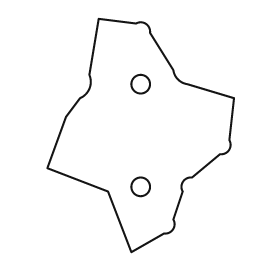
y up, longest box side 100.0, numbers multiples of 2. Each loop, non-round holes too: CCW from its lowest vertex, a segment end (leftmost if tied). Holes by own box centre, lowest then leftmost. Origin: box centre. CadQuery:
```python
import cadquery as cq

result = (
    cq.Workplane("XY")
    .moveTo(-4.0, -50.0)
    .lineTo(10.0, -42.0)
    .threePointArc((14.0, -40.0), (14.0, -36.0))
    .lineTo(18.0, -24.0)
    .threePointArc((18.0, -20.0), (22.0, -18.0))
    .lineTo(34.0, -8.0)
    .threePointArc((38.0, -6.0), (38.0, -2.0))
    .lineTo(40.0, 16.0)
    .lineTo(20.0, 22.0)
    .threePointArc((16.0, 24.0), (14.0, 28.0))
    .lineTo(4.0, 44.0)
    .threePointArc((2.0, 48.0), (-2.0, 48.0))
    .lineTo(-18.0, 50.0)
    .lineTo(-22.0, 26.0)
    .threePointArc((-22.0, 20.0), (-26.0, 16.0))
    .lineTo(-32.0, 8.0)
    .lineTo(-40.0, -14.0)
    .lineTo(-14.0, -24.0)
    .close()
    .moveTo(0.0, -22.0)
    .circle(4.0)
    .moveTo(0.0, 22.0)
    .circle(4.0)
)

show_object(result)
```